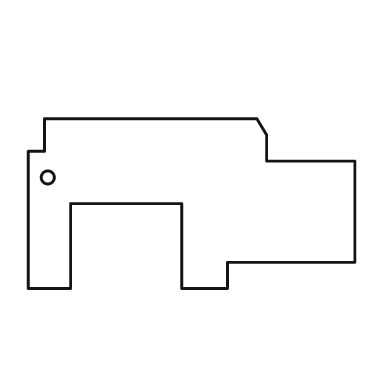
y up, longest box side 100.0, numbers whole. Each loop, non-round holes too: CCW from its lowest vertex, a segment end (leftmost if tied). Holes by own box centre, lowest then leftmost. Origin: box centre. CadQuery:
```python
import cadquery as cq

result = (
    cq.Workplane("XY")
    .moveTo(-50.0, -26.0)
    .lineTo(-37.0, -26.0)
    .lineTo(-37.0, 0.0)
    .lineTo(-3.0, 0.0)
    .lineTo(-3.0, -26.0)
    .lineTo(11.0, -26.0)
    .lineTo(11.0, -18.0)
    .lineTo(50.0, -18.0)
    .lineTo(50.0, 13.0)
    .lineTo(23.0, 13.0)
    .lineTo(23.0, 21.0)
    .lineTo(20.0, 26.0)
    .lineTo(-45.0, 26.0)
    .lineTo(-45.0, 16.0)
    .lineTo(-50.0, 16.0)
    .close()
    .moveTo(-44.0, 8.0)
    .circle(2.0)
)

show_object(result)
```